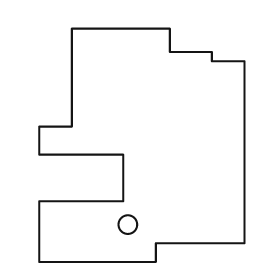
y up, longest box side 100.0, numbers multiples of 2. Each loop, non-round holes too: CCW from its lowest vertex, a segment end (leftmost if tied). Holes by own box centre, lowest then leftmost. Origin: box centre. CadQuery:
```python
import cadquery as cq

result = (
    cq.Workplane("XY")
    .moveTo(-44.0, -50.0)
    .lineTo(6.0, -50.0)
    .lineTo(6.0, -42.0)
    .lineTo(44.0, -42.0)
    .lineTo(44.0, 36.0)
    .lineTo(30.0, 36.0)
    .lineTo(30.0, 40.0)
    .lineTo(12.0, 40.0)
    .lineTo(12.0, 50.0)
    .lineTo(-30.0, 50.0)
    .lineTo(-30.0, 8.0)
    .lineTo(-44.0, 8.0)
    .lineTo(-44.0, -4.0)
    .lineTo(-8.0, -4.0)
    .lineTo(-8.0, -24.0)
    .lineTo(-44.0, -24.0)
    .close()
    .moveTo(-6.0, -34.0)
    .circle(4.0)
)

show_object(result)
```